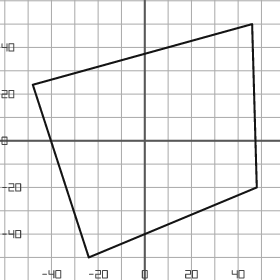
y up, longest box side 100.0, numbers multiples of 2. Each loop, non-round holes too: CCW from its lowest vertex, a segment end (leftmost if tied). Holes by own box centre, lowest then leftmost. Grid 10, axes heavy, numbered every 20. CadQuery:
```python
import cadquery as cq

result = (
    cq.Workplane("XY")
    .moveTo(-24.0, -50.0)
    .lineTo(48.0, -20.0)
    .lineTo(46.0, 50.0)
    .lineTo(-48.0, 24.0)
    .close()
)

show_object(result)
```